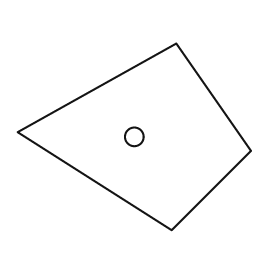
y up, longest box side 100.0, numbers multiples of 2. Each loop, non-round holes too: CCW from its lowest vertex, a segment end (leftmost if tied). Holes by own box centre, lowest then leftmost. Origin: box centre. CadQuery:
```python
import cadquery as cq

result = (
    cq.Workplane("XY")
    .moveTo(16.0, -40.0)
    .lineTo(50.0, -6.0)
    .lineTo(18.0, 40.0)
    .lineTo(-50.0, 2.0)
    .close()
    .moveTo(0.0, 0.0)
    .circle(4.0)
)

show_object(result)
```